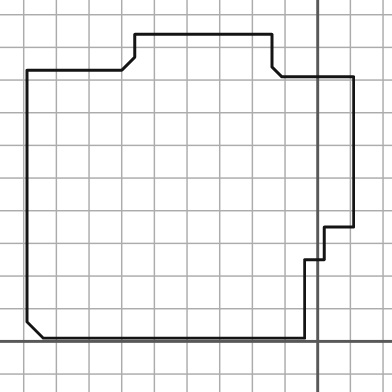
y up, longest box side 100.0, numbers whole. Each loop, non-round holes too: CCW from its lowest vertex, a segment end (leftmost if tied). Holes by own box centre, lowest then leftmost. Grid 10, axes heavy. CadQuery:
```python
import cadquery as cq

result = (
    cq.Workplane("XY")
    .moveTo(-84.0, 1.0)
    .lineTo(-4.0, 1.0)
    .lineTo(-4.0, 25.0)
    .lineTo(2.0, 25.0)
    .lineTo(2.0, 35.0)
    .lineTo(11.0, 35.0)
    .lineTo(11.0, 81.0)
    .lineTo(-11.0, 81.0)
    .lineTo(-14.0, 84.0)
    .lineTo(-14.0, 94.0)
    .lineTo(-56.0, 94.0)
    .lineTo(-56.0, 87.0)
    .lineTo(-60.0, 83.0)
    .lineTo(-89.0, 83.0)
    .lineTo(-89.0, 6.0)
    .close()
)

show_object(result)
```